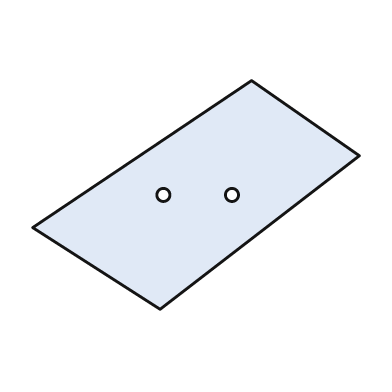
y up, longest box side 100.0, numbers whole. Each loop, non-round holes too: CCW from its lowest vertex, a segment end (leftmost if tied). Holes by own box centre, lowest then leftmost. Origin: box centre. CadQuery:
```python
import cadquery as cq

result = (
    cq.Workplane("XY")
    .moveTo(-11.0, -35.0)
    .lineTo(50.0, 12.0)
    .lineTo(17.0, 35.0)
    .lineTo(-50.0, -10.0)
    .close()
    .moveTo(-10.0, 0.0)
    .circle(2.0)
    .moveTo(11.0, 0.0)
    .circle(2.0)
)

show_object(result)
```